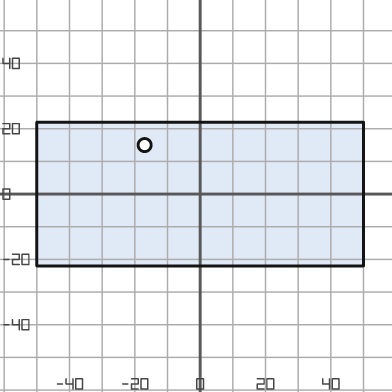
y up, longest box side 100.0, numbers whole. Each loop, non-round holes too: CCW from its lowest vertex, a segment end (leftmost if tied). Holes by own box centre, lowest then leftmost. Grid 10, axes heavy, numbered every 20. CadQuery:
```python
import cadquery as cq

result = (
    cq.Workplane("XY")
    .moveTo(-50.0, -22.0)
    .lineTo(50.0, -22.0)
    .lineTo(50.0, 22.0)
    .lineTo(-50.0, 22.0)
    .close()
    .moveTo(-17.0, 15.0)
    .circle(2.0)
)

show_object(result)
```